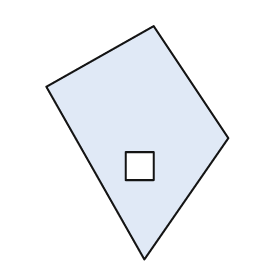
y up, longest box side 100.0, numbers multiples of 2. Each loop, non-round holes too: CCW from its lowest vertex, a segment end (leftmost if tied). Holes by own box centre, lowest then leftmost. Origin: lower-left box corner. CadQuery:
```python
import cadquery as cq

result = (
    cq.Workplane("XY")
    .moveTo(42.0, 0.0)
    .lineTo(78.0, 52.0)
    .lineTo(46.0, 100.0)
    .lineTo(0.0, 74.0)
    .close()
    .moveTo(34.0, 34.0)
    .lineTo(46.0, 34.0)
    .lineTo(46.0, 46.0)
    .lineTo(34.0, 46.0)
    .close()
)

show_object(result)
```